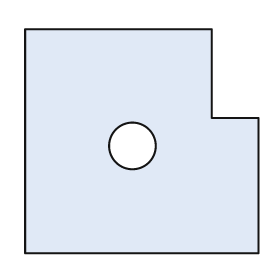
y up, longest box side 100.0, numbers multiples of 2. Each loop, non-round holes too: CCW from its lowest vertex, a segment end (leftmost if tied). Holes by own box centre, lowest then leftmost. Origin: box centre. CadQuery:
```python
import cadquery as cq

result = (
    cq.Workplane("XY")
    .moveTo(-50.0, -48.0)
    .lineTo(50.0, -48.0)
    .lineTo(50.0, 10.0)
    .lineTo(30.0, 10.0)
    .lineTo(30.0, 48.0)
    .lineTo(-50.0, 48.0)
    .close()
    .moveTo(-4.0, -2.0)
    .circle(10.0)
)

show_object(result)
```